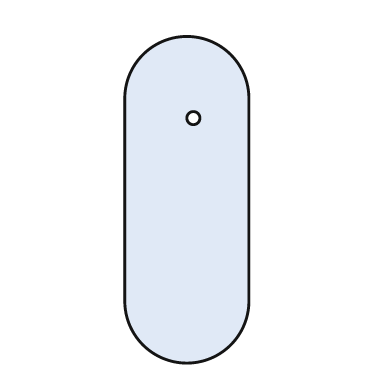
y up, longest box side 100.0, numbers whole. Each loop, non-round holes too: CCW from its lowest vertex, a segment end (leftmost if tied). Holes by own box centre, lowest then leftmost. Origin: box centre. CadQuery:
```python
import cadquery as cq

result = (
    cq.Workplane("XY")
    .moveTo(-19.0, -31.0)
    .threePointArc((0.0, -50.0), (19.0, -31.0))
    .lineTo(19.0, 31.0)
    .threePointArc((0.0, 50.0), (-19.0, 31.0))
    .close()
    .moveTo(2.0, 25.0)
    .circle(2.0)
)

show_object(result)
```